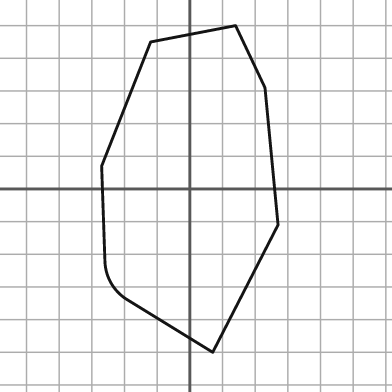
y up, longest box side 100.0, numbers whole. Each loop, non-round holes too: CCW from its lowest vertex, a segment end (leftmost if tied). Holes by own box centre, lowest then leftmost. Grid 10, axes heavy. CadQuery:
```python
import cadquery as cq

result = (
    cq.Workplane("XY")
    .moveTo(7.0, -50.0)
    .lineTo(27.0, -11.0)
    .lineTo(23.0, 31.0)
    .lineTo(14.0, 50.0)
    .lineTo(-12.0, 45.0)
    .lineTo(-27.0, 7.0)
    .lineTo(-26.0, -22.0)
    .threePointArc((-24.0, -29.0), (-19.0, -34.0))
    .close()
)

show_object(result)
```